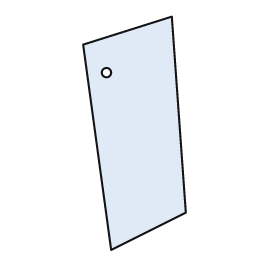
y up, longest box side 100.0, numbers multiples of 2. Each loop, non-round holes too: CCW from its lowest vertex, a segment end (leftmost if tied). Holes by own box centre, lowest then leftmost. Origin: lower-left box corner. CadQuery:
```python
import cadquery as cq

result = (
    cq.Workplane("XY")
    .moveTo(12.0, 0.0)
    .lineTo(44.0, 16.0)
    .lineTo(38.0, 100.0)
    .lineTo(0.0, 88.0)
    .close()
    .moveTo(10.0, 76.0)
    .circle(2.0)
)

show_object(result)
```